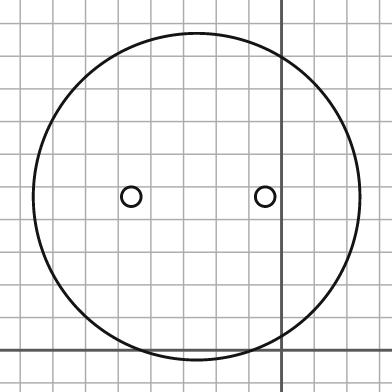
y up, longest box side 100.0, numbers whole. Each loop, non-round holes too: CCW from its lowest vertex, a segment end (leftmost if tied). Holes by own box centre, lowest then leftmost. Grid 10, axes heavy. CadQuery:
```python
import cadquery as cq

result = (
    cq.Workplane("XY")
    .moveTo(-26.0, 47.0)
    .circle(50.0)
    .moveTo(-46.0, 47.0)
    .circle(3.0)
    .moveTo(-5.0, 47.0)
    .circle(3.0)
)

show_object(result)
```